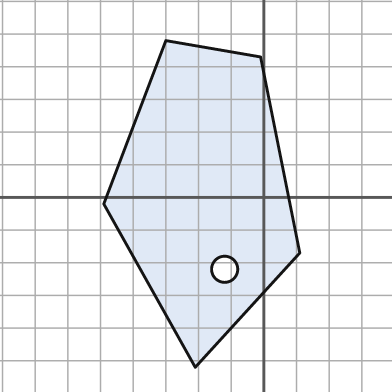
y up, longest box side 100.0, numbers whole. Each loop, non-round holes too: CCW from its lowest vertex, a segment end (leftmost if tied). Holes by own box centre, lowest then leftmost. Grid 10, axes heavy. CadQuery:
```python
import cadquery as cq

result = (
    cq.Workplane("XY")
    .moveTo(-21.0, -52.0)
    .lineTo(11.0, -17.0)
    .lineTo(-1.0, 43.0)
    .lineTo(-30.0, 48.0)
    .lineTo(-49.0, -2.0)
    .close()
    .moveTo(-12.0, -22.0)
    .circle(4.0)
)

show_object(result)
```